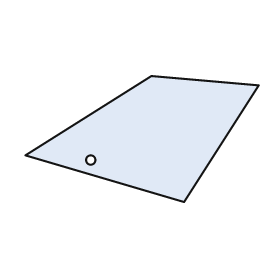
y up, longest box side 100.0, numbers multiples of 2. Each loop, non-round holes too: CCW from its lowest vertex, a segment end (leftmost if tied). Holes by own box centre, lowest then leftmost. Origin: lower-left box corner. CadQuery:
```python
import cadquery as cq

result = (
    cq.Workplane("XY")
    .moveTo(68.0, 0.0)
    .lineTo(100.0, 50.0)
    .lineTo(54.0, 54.0)
    .lineTo(0.0, 20.0)
    .close()
    .moveTo(28.0, 18.0)
    .circle(2.0)
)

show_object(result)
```